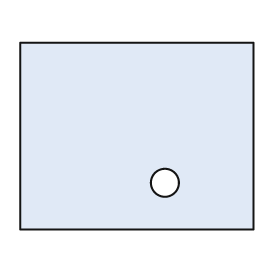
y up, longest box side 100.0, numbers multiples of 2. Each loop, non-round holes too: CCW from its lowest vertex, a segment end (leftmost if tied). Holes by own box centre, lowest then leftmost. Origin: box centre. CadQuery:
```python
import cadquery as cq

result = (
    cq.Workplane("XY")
    .moveTo(-50.0, -40.0)
    .lineTo(50.0, -40.0)
    .lineTo(50.0, 40.0)
    .lineTo(-50.0, 40.0)
    .close()
    .moveTo(12.0, -20.0)
    .circle(6.0)
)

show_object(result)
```